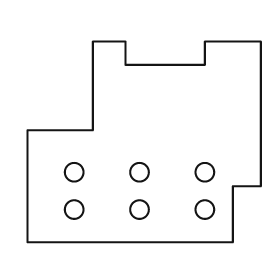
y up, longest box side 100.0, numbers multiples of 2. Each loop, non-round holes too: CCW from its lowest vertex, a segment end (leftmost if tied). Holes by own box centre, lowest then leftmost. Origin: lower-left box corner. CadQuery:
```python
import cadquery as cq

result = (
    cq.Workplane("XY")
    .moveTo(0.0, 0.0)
    .lineTo(88.0, 0.0)
    .lineTo(88.0, 24.0)
    .lineTo(100.0, 24.0)
    .lineTo(100.0, 86.0)
    .lineTo(76.0, 86.0)
    .lineTo(76.0, 76.0)
    .lineTo(42.0, 76.0)
    .lineTo(42.0, 86.0)
    .lineTo(28.0, 86.0)
    .lineTo(28.0, 48.0)
    .lineTo(0.0, 48.0)
    .close()
    .moveTo(20.0, 14.0)
    .circle(4.0)
    .moveTo(48.0, 14.0)
    .circle(4.0)
    .moveTo(76.0, 14.0)
    .circle(4.0)
    .moveTo(20.0, 30.0)
    .circle(4.0)
    .moveTo(48.0, 30.0)
    .circle(4.0)
    .moveTo(76.0, 30.0)
    .circle(4.0)
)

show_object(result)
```